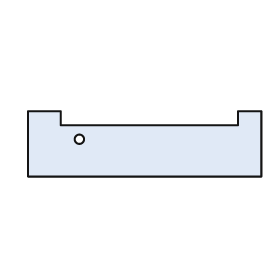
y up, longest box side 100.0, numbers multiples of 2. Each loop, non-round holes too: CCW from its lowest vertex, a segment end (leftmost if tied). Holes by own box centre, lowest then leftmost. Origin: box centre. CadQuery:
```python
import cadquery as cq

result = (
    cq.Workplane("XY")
    .moveTo(-50.0, -14.0)
    .lineTo(50.0, -14.0)
    .lineTo(50.0, 14.0)
    .lineTo(40.0, 14.0)
    .lineTo(40.0, 8.0)
    .lineTo(-36.0, 8.0)
    .lineTo(-36.0, 14.0)
    .lineTo(-50.0, 14.0)
    .close()
    .moveTo(-28.0, 2.0)
    .circle(2.0)
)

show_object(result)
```